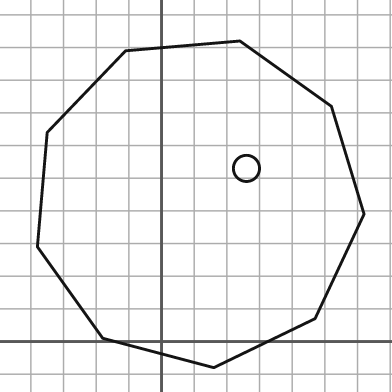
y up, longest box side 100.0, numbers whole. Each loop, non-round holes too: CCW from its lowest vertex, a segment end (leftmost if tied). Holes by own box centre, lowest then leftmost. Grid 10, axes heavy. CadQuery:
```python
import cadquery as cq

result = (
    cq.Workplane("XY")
    .moveTo(16.0, -8.0)
    .lineTo(47.0, 7.0)
    .lineTo(62.0, 39.0)
    .lineTo(52.0, 72.0)
    .lineTo(24.0, 92.0)
    .lineTo(-11.0, 89.0)
    .lineTo(-35.0, 64.0)
    .lineTo(-38.0, 29.0)
    .lineTo(-18.0, 1.0)
    .close()
    .moveTo(26.0, 53.0)
    .circle(4.0)
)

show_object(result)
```